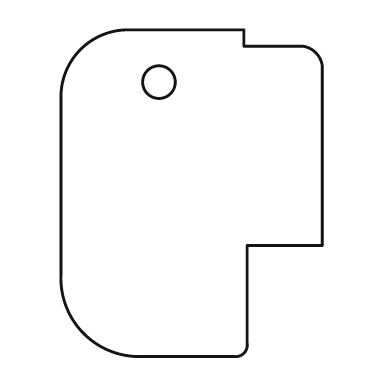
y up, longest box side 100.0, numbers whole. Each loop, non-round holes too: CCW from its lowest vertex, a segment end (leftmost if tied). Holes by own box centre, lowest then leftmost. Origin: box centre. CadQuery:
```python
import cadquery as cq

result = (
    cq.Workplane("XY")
    .moveTo(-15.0, -50.0)
    .lineTo(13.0, -50.0)
    .threePointArc((16.0, -49.0), (17.0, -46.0))
    .lineTo(17.0, -16.0)
    .lineTo(40.0, -16.0)
    .lineTo(40.0, 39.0)
    .threePointArc((38.0, 43.0), (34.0, 45.0))
    .lineTo(16.0, 45.0)
    .lineTo(16.0, 50.0)
    .lineTo(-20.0, 50.0)
    .threePointArc((-34.0, 44.0), (-40.0, 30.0))
    .lineTo(-40.0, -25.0)
    .threePointArc((-33.0, -43.0), (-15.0, -50.0))
    .close()
    .moveTo(-10.0, 34.0)
    .circle(5.0)
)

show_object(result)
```